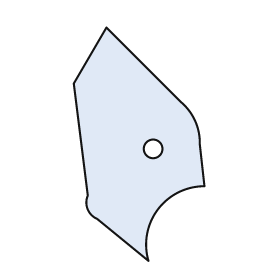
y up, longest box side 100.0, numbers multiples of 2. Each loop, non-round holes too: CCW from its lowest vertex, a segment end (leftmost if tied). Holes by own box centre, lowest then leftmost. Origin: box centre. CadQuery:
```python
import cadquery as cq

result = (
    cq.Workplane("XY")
    .moveTo(4.0, -50.0)
    .threePointArc((8.0, -28.0), (28.0, -18.0))
    .lineTo(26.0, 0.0)
    .threePointArc((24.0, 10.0), (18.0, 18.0))
    .lineTo(-14.0, 50.0)
    .lineTo(-28.0, 26.0)
    .lineTo(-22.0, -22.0)
    .threePointArc((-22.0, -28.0), (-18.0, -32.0))
    .close()
    .moveTo(6.0, -2.0)
    .circle(4.0)
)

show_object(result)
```